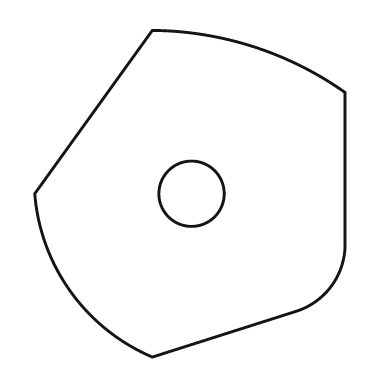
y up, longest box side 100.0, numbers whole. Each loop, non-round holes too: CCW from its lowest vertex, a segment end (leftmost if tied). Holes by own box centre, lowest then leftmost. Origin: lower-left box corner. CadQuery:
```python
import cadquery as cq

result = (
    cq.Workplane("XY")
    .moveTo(36.0, 0.0)
    .lineTo(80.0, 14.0)
    .threePointArc((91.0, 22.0), (95.0, 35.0))
    .lineTo(95.0, 81.0)
    .threePointArc((67.0, 95.0), (36.0, 100.0))
    .lineTo(0.0, 50.0)
    .threePointArc((11.0, 20.0), (36.0, 0.0))
    .close()
    .moveTo(48.0, 50.0)
    .circle(10.0)
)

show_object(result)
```